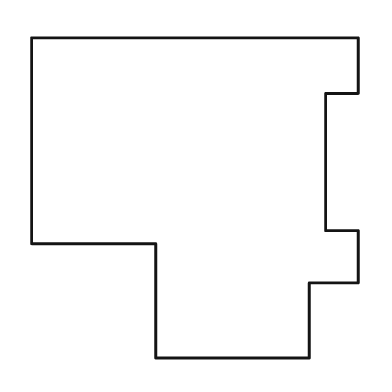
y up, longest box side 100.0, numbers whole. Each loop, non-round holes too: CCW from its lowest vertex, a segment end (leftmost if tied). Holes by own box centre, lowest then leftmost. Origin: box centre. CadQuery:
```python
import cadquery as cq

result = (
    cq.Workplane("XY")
    .moveTo(-12.0, -49.0)
    .lineTo(35.0, -49.0)
    .lineTo(35.0, -26.0)
    .lineTo(50.0, -26.0)
    .lineTo(50.0, -10.0)
    .lineTo(40.0, -10.0)
    .lineTo(40.0, 32.0)
    .lineTo(50.0, 32.0)
    .lineTo(50.0, 49.0)
    .lineTo(-50.0, 49.0)
    .lineTo(-50.0, -14.0)
    .lineTo(-12.0, -14.0)
    .close()
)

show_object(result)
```